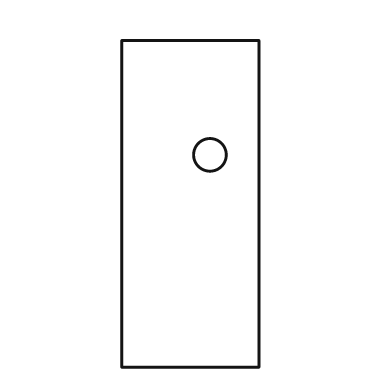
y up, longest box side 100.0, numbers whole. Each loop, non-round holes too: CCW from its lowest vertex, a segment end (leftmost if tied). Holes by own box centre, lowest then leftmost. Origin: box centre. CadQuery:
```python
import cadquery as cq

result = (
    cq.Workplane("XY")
    .moveTo(-21.0, -50.0)
    .lineTo(21.0, -50.0)
    .lineTo(21.0, 50.0)
    .lineTo(-21.0, 50.0)
    .close()
    .moveTo(6.0, 15.0)
    .circle(5.0)
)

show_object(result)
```